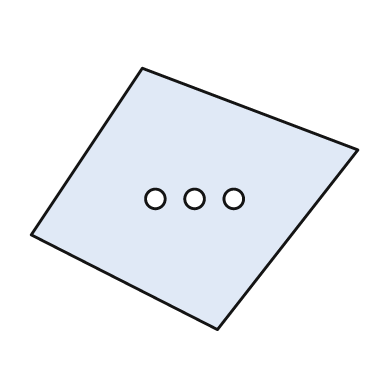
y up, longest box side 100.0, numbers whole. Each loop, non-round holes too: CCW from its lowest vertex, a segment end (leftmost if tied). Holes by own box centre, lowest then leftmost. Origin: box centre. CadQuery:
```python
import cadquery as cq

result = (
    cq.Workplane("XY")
    .moveTo(7.0, -40.0)
    .lineTo(50.0, 15.0)
    .lineTo(-16.0, 40.0)
    .lineTo(-50.0, -11.0)
    .close()
    .moveTo(-12.0, 0.0)
    .circle(3.0)
    .moveTo(0.0, 0.0)
    .circle(3.0)
    .moveTo(12.0, 0.0)
    .circle(3.0)
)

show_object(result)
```